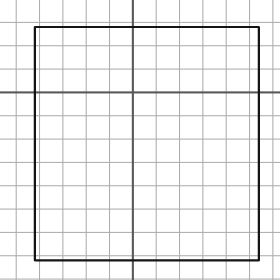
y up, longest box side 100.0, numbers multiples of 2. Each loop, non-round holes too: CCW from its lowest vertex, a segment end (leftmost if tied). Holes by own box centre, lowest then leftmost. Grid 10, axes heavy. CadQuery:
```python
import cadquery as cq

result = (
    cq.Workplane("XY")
    .moveTo(-42.0, -72.0)
    .lineTo(54.0, -72.0)
    .lineTo(54.0, 28.0)
    .lineTo(-42.0, 28.0)
    .close()
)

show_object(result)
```